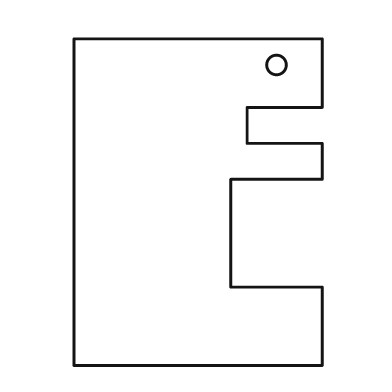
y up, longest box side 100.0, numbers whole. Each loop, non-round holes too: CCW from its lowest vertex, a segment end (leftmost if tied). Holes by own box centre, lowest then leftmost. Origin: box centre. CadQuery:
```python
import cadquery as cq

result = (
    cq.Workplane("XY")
    .moveTo(-38.0, -50.0)
    .lineTo(38.0, -50.0)
    .lineTo(38.0, -26.0)
    .lineTo(10.0, -26.0)
    .lineTo(10.0, 7.0)
    .lineTo(38.0, 7.0)
    .lineTo(38.0, 18.0)
    .lineTo(15.0, 18.0)
    .lineTo(15.0, 29.0)
    .lineTo(38.0, 29.0)
    .lineTo(38.0, 50.0)
    .lineTo(-38.0, 50.0)
    .close()
    .moveTo(24.0, 42.0)
    .circle(3.0)
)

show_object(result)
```